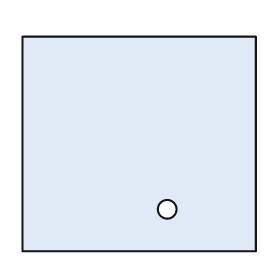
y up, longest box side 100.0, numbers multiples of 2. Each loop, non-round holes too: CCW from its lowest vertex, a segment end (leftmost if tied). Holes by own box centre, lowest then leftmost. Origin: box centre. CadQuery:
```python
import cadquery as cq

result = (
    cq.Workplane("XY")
    .moveTo(-50.0, -46.0)
    .lineTo(50.0, -46.0)
    .lineTo(50.0, 46.0)
    .lineTo(-50.0, 46.0)
    .close()
    .moveTo(12.0, -28.0)
    .circle(4.0)
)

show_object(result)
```